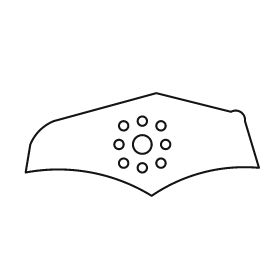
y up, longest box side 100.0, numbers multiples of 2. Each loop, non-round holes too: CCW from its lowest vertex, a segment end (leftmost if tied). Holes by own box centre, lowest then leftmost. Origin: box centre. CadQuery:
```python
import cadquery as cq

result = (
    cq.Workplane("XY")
    .moveTo(4.0, -22.0)
    .threePointArc((26.0, -12.0), (50.0, -10.0))
    .lineTo(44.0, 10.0)
    .threePointArc((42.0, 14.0), (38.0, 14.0))
    .lineTo(6.0, 22.0)
    .lineTo(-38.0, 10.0)
    .threePointArc((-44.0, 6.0), (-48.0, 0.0))
    .lineTo(-50.0, -12.0)
    .threePointArc((-22.0, -12.0), (4.0, -22.0))
    .close()
    .moveTo(0.0, -10.0)
    .circle(2.0)
    .moveTo(-8.0, -8.0)
    .circle(2.0)
    .moveTo(8.0, -8.0)
    .circle(2.0)
    .moveTo(-10.0, 0.0)
    .circle(2.0)
    .moveTo(0.0, 0.0)
    .circle(4.0)
    .moveTo(10.0, 0.0)
    .circle(2.0)
    .moveTo(-8.0, 8.0)
    .circle(2.0)
    .moveTo(8.0, 8.0)
    .circle(2.0)
    .moveTo(0.0, 10.0)
    .circle(2.0)
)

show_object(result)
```